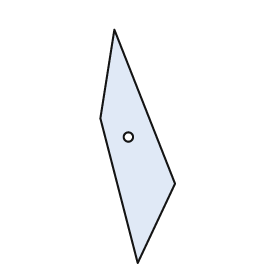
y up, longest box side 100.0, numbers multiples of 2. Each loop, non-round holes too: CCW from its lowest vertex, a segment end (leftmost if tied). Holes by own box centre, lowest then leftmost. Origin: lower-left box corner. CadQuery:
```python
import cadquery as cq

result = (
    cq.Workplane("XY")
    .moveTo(16.0, 0.0)
    .lineTo(32.0, 34.0)
    .lineTo(6.0, 100.0)
    .lineTo(0.0, 62.0)
    .close()
    .moveTo(12.0, 54.0)
    .circle(2.0)
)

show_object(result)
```